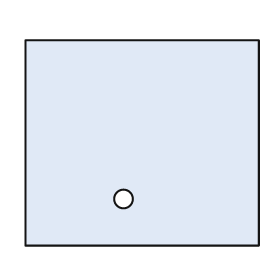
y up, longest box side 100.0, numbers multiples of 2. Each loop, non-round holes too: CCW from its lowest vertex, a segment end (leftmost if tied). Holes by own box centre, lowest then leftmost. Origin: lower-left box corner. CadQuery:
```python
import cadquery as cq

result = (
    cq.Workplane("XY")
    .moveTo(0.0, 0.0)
    .lineTo(100.0, 0.0)
    .lineTo(100.0, 88.0)
    .lineTo(0.0, 88.0)
    .close()
    .moveTo(42.0, 20.0)
    .circle(4.0)
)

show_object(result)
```